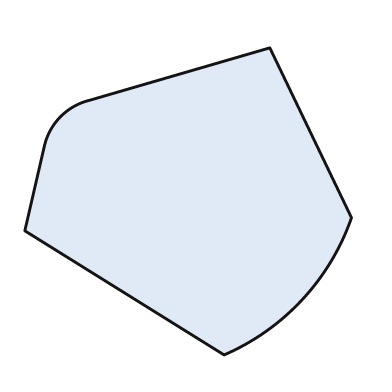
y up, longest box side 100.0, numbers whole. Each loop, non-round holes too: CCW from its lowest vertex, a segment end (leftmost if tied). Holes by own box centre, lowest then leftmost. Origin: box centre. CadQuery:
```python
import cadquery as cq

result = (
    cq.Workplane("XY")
    .moveTo(11.0, -47.0)
    .threePointArc((35.0, -30.0), (50.0, -5.0))
    .lineTo(25.0, 47.0)
    .lineTo(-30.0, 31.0)
    .threePointArc((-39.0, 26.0), (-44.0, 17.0))
    .lineTo(-50.0, -9.0)
    .close()
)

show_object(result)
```